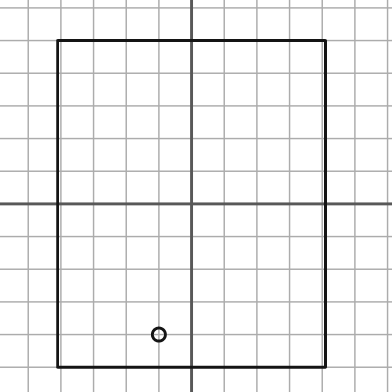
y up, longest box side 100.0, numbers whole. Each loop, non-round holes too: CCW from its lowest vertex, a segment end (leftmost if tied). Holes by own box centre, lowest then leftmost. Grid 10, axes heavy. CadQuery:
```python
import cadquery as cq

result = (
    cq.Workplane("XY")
    .moveTo(-41.0, -50.0)
    .lineTo(41.0, -50.0)
    .lineTo(41.0, 50.0)
    .lineTo(-41.0, 50.0)
    .close()
    .moveTo(-10.0, -40.0)
    .circle(2.0)
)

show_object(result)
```